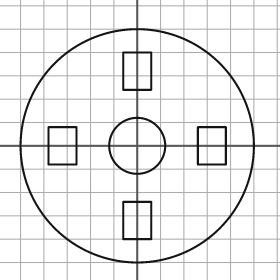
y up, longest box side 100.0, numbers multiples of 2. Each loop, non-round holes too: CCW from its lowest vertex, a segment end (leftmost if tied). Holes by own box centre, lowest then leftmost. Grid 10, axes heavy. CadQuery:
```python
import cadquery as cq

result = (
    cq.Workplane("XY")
    .moveTo(0.0, 0.0)
    .circle(50.0)
    .moveTo(-6.0, -40.0)
    .lineTo(6.0, -40.0)
    .lineTo(6.0, -24.0)
    .lineTo(-6.0, -24.0)
    .close()
    .moveTo(-38.0, -8.0)
    .lineTo(-26.0, -8.0)
    .lineTo(-26.0, 8.0)
    .lineTo(-38.0, 8.0)
    .close()
    .moveTo(0.0, 0.0)
    .circle(12.0)
    .moveTo(26.0, -8.0)
    .lineTo(38.0, -8.0)
    .lineTo(38.0, 8.0)
    .lineTo(26.0, 8.0)
    .close()
    .moveTo(-6.0, 24.0)
    .lineTo(6.0, 24.0)
    .lineTo(6.0, 40.0)
    .lineTo(-6.0, 40.0)
    .close()
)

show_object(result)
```